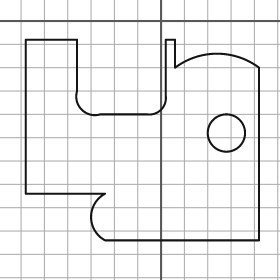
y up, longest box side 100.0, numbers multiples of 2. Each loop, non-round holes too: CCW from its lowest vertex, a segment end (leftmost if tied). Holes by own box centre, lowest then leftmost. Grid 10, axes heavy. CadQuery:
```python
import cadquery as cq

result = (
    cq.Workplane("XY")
    .moveTo(-24.0, -94.0)
    .lineTo(42.0, -94.0)
    .lineTo(42.0, -20.0)
    .threePointArc((24.0, -14.0), (6.0, -20.0))
    .lineTo(6.0, -8.0)
    .lineTo(2.0, -8.0)
    .lineTo(2.0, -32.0)
    .threePointArc((0.0, -38.0), (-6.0, -40.0))
    .lineTo(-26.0, -40.0)
    .threePointArc((-34.0, -38.0), (-36.0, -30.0))
    .lineTo(-36.0, -8.0)
    .lineTo(-58.0, -8.0)
    .lineTo(-58.0, -74.0)
    .lineTo(-24.0, -74.0)
    .threePointArc((-30.0, -84.0), (-24.0, -94.0))
    .close()
    .moveTo(28.0, -48.0)
    .circle(8.0)
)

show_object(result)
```